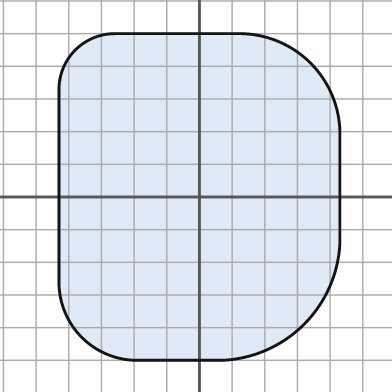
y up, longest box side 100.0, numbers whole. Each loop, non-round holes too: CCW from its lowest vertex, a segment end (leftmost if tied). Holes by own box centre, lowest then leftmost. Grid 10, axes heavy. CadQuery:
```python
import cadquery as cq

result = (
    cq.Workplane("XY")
    .moveTo(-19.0, -50.0)
    .lineTo(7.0, -50.0)
    .threePointArc((32.0, -39.0), (43.0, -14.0))
    .lineTo(43.0, 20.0)
    .threePointArc((34.0, 41.0), (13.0, 50.0))
    .lineTo(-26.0, 50.0)
    .threePointArc((-38.0, 45.0), (-43.0, 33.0))
    .lineTo(-43.0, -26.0)
    .threePointArc((-36.0, -43.0), (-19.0, -50.0))
    .close()
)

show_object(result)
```